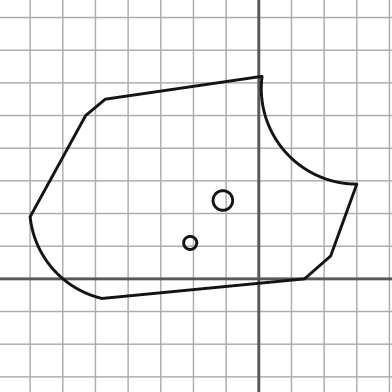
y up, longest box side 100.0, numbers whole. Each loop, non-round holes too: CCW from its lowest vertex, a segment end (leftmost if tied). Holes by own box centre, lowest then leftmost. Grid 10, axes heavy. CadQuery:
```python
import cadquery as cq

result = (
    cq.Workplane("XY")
    .moveTo(-48.0, -6.0)
    .lineTo(14.0, 0.0)
    .lineTo(22.0, 7.0)
    .lineTo(30.0, 29.0)
    .threePointArc((8.0, 39.0), (1.0, 62.0))
    .lineTo(-47.0, 55.0)
    .lineTo(-53.0, 50.0)
    .lineTo(-70.0, 19.0)
    .threePointArc((-63.0, 3.0), (-48.0, -6.0))
    .close()
    .moveTo(-21.0, 11.0)
    .circle(2.0)
    .moveTo(-11.0, 24.0)
    .circle(3.0)
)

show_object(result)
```